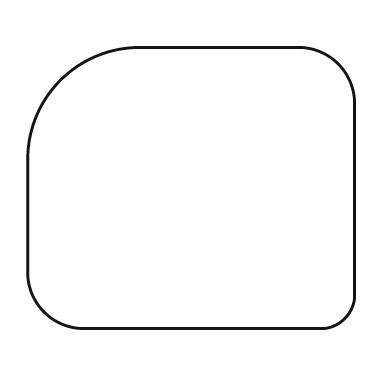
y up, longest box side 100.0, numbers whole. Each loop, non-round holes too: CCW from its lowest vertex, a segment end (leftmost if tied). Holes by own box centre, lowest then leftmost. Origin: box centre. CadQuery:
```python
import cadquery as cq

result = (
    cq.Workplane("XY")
    .moveTo(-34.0, -43.0)
    .lineTo(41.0, -43.0)
    .threePointArc((47.0, -40.0), (50.0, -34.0))
    .lineTo(50.0, 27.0)
    .threePointArc((45.0, 38.0), (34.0, 43.0))
    .lineTo(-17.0, 43.0)
    .threePointArc((-40.0, 33.0), (-50.0, 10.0))
    .lineTo(-50.0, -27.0)
    .threePointArc((-45.0, -38.0), (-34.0, -43.0))
    .close()
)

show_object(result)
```